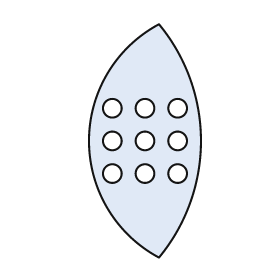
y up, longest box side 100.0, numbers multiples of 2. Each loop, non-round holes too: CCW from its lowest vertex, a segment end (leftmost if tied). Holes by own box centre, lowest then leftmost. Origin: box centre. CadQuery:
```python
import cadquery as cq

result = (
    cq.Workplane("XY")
    .moveTo(6.0, -50.0)
    .threePointArc((24.0, 0.0), (6.0, 50.0))
    .threePointArc((-24.0, 0.0), (6.0, -50.0))
    .close()
    .moveTo(-14.0, -14.0)
    .circle(4.0)
    .moveTo(0.0, -14.0)
    .circle(4.0)
    .moveTo(14.0, -14.0)
    .circle(4.0)
    .moveTo(-14.0, 0.0)
    .circle(4.0)
    .moveTo(0.0, 0.0)
    .circle(4.0)
    .moveTo(14.0, 0.0)
    .circle(4.0)
    .moveTo(-14.0, 14.0)
    .circle(4.0)
    .moveTo(0.0, 14.0)
    .circle(4.0)
    .moveTo(14.0, 14.0)
    .circle(4.0)
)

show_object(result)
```